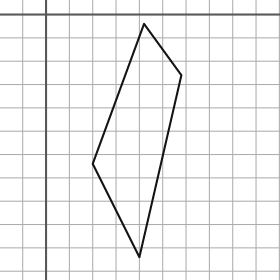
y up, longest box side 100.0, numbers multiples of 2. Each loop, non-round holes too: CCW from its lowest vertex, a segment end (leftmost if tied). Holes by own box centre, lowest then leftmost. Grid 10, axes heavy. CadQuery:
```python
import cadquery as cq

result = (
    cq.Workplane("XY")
    .moveTo(40.0, -104.0)
    .lineTo(58.0, -26.0)
    .lineTo(42.0, -4.0)
    .lineTo(20.0, -64.0)
    .close()
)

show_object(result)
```